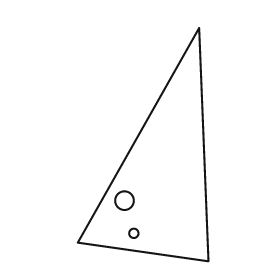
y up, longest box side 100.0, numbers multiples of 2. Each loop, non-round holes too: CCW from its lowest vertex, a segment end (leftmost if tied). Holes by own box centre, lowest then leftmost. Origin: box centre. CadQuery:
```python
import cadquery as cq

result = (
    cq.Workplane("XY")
    .moveTo(28.0, -50.0)
    .lineTo(24.0, 50.0)
    .lineTo(-28.0, -42.0)
    .close()
    .moveTo(-4.0, -38.0)
    .circle(2.0)
    .moveTo(-8.0, -24.0)
    .circle(4.0)
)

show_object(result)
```